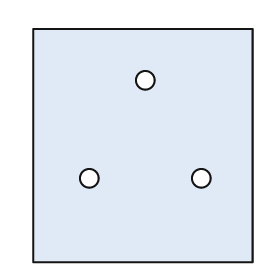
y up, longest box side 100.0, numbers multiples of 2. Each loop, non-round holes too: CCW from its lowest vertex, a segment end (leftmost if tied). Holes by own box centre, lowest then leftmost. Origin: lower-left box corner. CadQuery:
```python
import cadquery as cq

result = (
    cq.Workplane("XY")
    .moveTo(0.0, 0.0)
    .lineTo(94.0, 0.0)
    .lineTo(94.0, 100.0)
    .lineTo(0.0, 100.0)
    .close()
    .moveTo(24.0, 36.0)
    .circle(4.0)
    .moveTo(72.0, 36.0)
    .circle(4.0)
    .moveTo(48.0, 78.0)
    .circle(4.0)
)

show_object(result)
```